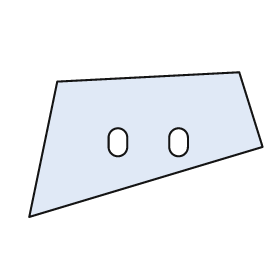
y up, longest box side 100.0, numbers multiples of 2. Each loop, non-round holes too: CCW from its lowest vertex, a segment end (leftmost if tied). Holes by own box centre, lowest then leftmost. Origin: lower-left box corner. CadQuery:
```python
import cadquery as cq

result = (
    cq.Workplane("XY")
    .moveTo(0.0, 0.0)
    .lineTo(100.0, 30.0)
    .lineTo(90.0, 62.0)
    .lineTo(12.0, 58.0)
    .close()
    .moveTo(34.0, 30.0)
    .threePointArc((38.0, 26.0), (42.0, 30.0))
    .lineTo(42.0, 34.0)
    .threePointArc((38.0, 38.0), (34.0, 34.0))
    .close()
    .moveTo(60.0, 30.0)
    .threePointArc((64.0, 26.0), (68.0, 30.0))
    .lineTo(68.0, 34.0)
    .threePointArc((64.0, 38.0), (60.0, 34.0))
    .close()
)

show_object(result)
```